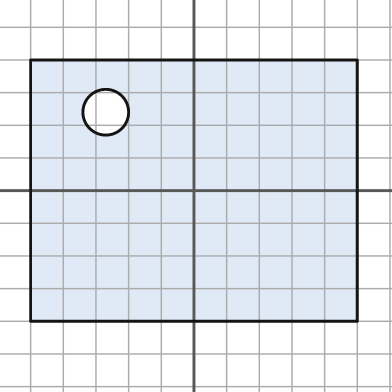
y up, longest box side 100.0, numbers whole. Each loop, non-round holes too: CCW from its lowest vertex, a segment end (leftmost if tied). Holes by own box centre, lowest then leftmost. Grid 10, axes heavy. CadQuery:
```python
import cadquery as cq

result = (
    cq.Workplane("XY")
    .moveTo(-50.0, -40.0)
    .lineTo(50.0, -40.0)
    .lineTo(50.0, 40.0)
    .lineTo(-50.0, 40.0)
    .close()
    .moveTo(-27.0, 24.0)
    .circle(7.0)
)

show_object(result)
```